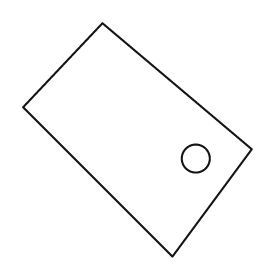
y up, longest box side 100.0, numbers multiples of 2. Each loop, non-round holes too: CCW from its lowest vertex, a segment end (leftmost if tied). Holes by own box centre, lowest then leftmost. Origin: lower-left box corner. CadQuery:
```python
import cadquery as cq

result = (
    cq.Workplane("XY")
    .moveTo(64.0, 0.0)
    .lineTo(98.0, 46.0)
    .lineTo(34.0, 100.0)
    .lineTo(0.0, 64.0)
    .close()
    .moveTo(74.0, 42.0)
    .circle(6.0)
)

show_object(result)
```